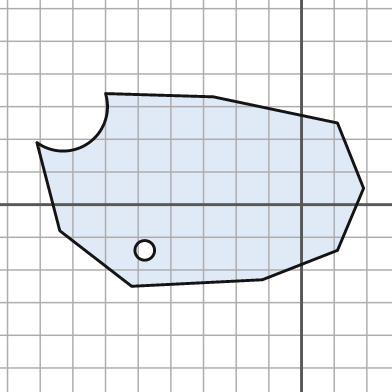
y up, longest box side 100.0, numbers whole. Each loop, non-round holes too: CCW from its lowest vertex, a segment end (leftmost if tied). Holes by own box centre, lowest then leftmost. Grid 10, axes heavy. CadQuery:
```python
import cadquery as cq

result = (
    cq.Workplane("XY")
    .moveTo(-52.0, -25.0)
    .lineTo(-12.0, -23.0)
    .lineTo(11.0, -14.0)
    .lineTo(19.0, 5.0)
    .lineTo(11.0, 25.0)
    .lineTo(-27.0, 33.0)
    .lineTo(-60.0, 34.0)
    .threePointArc((-65.0, 19.0), (-81.0, 19.0))
    .lineTo(-74.0, -8.0)
    .close()
    .moveTo(-48.0, -14.0)
    .circle(3.0)
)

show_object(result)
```